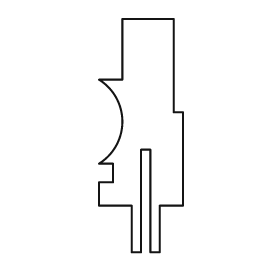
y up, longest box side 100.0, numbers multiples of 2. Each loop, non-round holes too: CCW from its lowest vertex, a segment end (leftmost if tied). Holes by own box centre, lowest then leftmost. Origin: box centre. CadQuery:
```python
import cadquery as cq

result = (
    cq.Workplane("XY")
    .moveTo(-4.0, -50.0)
    .lineTo(0.0, -50.0)
    .lineTo(0.0, -6.0)
    .lineTo(4.0, -6.0)
    .lineTo(4.0, -50.0)
    .lineTo(8.0, -50.0)
    .lineTo(8.0, -30.0)
    .lineTo(18.0, -30.0)
    .lineTo(18.0, 10.0)
    .lineTo(14.0, 10.0)
    .lineTo(14.0, 50.0)
    .lineTo(-8.0, 50.0)
    .lineTo(-8.0, 24.0)
    .lineTo(-18.0, 24.0)
    .threePointArc((-8.0, 6.0), (-18.0, -12.0))
    .lineTo(-12.0, -12.0)
    .lineTo(-12.0, -20.0)
    .lineTo(-18.0, -20.0)
    .lineTo(-18.0, -30.0)
    .lineTo(-4.0, -30.0)
    .close()
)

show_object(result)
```